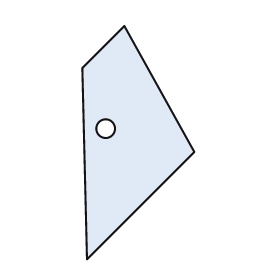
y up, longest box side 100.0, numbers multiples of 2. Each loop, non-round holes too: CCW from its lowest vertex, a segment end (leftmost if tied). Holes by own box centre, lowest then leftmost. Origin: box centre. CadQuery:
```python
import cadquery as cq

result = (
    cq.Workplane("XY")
    .moveTo(-22.0, -50.0)
    .lineTo(24.0, -4.0)
    .lineTo(-6.0, 50.0)
    .lineTo(-24.0, 32.0)
    .close()
    .moveTo(-14.0, 6.0)
    .circle(4.0)
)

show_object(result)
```